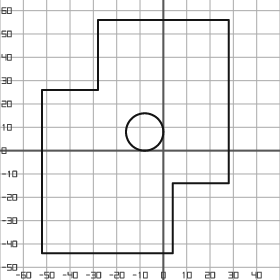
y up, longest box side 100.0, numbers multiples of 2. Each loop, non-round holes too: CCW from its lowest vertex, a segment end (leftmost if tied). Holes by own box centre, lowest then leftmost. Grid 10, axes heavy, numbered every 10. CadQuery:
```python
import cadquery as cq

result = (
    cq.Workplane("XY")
    .moveTo(-52.0, -44.0)
    .lineTo(4.0, -44.0)
    .lineTo(4.0, -14.0)
    .lineTo(28.0, -14.0)
    .lineTo(28.0, 56.0)
    .lineTo(-28.0, 56.0)
    .lineTo(-28.0, 26.0)
    .lineTo(-52.0, 26.0)
    .close()
    .moveTo(-8.0, 8.0)
    .circle(8.0)
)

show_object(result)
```